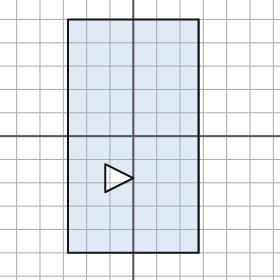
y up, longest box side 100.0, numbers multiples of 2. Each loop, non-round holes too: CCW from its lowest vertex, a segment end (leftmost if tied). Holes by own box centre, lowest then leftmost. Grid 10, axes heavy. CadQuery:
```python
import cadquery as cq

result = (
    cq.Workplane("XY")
    .moveTo(-28.0, -50.0)
    .lineTo(28.0, -50.0)
    .lineTo(28.0, 50.0)
    .lineTo(-28.0, 50.0)
    .close()
    .moveTo(-12.0, -24.0)
    .lineTo(0.0, -18.0)
    .lineTo(-12.0, -12.0)
    .close()
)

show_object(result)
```